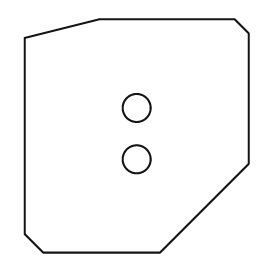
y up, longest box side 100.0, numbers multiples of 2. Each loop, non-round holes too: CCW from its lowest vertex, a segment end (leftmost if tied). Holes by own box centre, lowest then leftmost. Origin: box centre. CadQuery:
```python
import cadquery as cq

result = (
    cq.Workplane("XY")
    .moveTo(-40.0, -50.0)
    .lineTo(10.0, -50.0)
    .lineTo(48.0, -12.0)
    .lineTo(48.0, 44.0)
    .lineTo(42.0, 50.0)
    .lineTo(-16.0, 50.0)
    .lineTo(-48.0, 42.0)
    .lineTo(-48.0, -42.0)
    .close()
    .moveTo(0.0, -10.0)
    .circle(6.0)
    .moveTo(0.0, 12.0)
    .circle(6.0)
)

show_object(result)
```